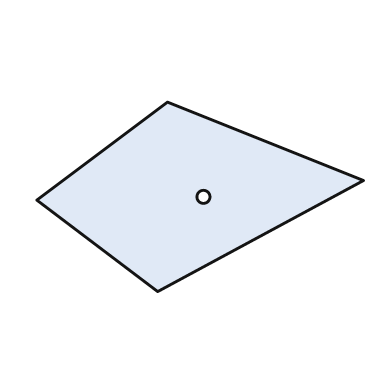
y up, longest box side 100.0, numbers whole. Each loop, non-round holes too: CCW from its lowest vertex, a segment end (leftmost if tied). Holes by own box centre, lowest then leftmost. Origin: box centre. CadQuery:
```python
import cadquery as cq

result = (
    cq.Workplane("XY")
    .moveTo(-13.0, -29.0)
    .lineTo(50.0, 5.0)
    .lineTo(-10.0, 29.0)
    .lineTo(-50.0, -1.0)
    .close()
    .moveTo(1.0, 0.0)
    .circle(2.0)
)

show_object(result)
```